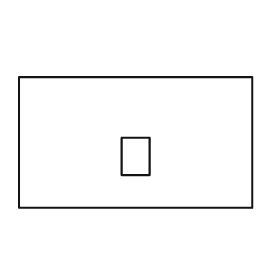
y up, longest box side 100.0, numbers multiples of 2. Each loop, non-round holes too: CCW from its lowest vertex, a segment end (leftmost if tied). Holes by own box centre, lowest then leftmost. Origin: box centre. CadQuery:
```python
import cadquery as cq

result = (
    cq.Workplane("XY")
    .moveTo(-50.0, -28.0)
    .lineTo(50.0, -28.0)
    .lineTo(50.0, 28.0)
    .lineTo(-50.0, 28.0)
    .close()
    .moveTo(-6.0, -14.0)
    .lineTo(6.0, -14.0)
    .lineTo(6.0, 2.0)
    .lineTo(-6.0, 2.0)
    .close()
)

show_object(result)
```